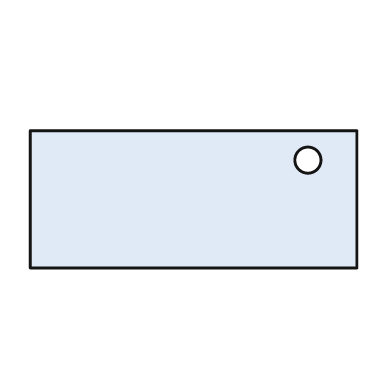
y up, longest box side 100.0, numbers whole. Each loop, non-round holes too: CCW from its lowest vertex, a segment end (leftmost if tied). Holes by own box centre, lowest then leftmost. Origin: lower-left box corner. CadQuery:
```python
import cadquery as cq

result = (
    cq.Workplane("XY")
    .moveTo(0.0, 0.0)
    .lineTo(100.0, 0.0)
    .lineTo(100.0, 42.0)
    .lineTo(0.0, 42.0)
    .close()
    .moveTo(85.0, 33.0)
    .circle(4.0)
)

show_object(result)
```